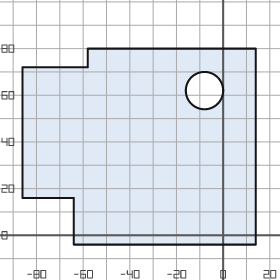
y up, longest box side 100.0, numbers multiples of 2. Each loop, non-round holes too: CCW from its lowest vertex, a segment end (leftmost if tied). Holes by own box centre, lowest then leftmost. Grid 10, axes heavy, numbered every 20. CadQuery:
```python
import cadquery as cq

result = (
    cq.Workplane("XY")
    .moveTo(-64.0, -4.0)
    .lineTo(14.0, -4.0)
    .lineTo(14.0, 80.0)
    .lineTo(-58.0, 80.0)
    .lineTo(-58.0, 72.0)
    .lineTo(-86.0, 72.0)
    .lineTo(-86.0, 16.0)
    .lineTo(-64.0, 16.0)
    .close()
    .moveTo(-8.0, 62.0)
    .circle(8.0)
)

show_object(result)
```